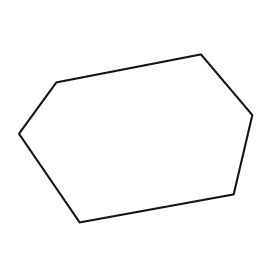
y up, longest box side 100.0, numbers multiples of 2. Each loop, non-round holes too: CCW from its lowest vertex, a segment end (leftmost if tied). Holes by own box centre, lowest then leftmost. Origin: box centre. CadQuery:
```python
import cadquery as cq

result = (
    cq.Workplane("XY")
    .moveTo(-24.0, -36.0)
    .lineTo(42.0, -24.0)
    .lineTo(50.0, 10.0)
    .lineTo(28.0, 36.0)
    .lineTo(-34.0, 24.0)
    .lineTo(-50.0, 2.0)
    .close()
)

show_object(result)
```